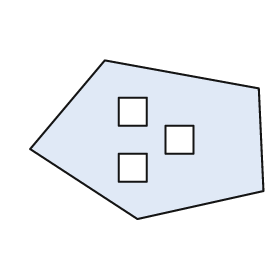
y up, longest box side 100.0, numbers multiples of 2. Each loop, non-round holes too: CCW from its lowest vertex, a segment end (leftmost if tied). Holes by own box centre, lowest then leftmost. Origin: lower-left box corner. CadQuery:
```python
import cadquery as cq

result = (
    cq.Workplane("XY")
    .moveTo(46.0, 0.0)
    .lineTo(100.0, 12.0)
    .lineTo(98.0, 56.0)
    .lineTo(32.0, 68.0)
    .lineTo(0.0, 30.0)
    .close()
    .moveTo(38.0, 16.0)
    .lineTo(50.0, 16.0)
    .lineTo(50.0, 28.0)
    .lineTo(38.0, 28.0)
    .close()
    .moveTo(58.0, 28.0)
    .lineTo(70.0, 28.0)
    .lineTo(70.0, 40.0)
    .lineTo(58.0, 40.0)
    .close()
    .moveTo(38.0, 40.0)
    .lineTo(50.0, 40.0)
    .lineTo(50.0, 52.0)
    .lineTo(38.0, 52.0)
    .close()
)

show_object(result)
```